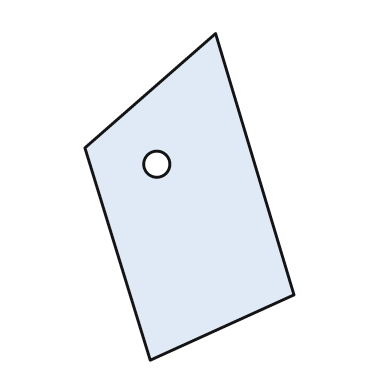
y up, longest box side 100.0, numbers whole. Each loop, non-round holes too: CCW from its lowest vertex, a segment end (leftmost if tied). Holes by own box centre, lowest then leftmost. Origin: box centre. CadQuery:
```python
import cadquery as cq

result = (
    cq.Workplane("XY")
    .moveTo(-12.0, -50.0)
    .lineTo(32.0, -30.0)
    .lineTo(8.0, 50.0)
    .lineTo(-32.0, 15.0)
    .close()
    .moveTo(-10.0, 10.0)
    .circle(4.0)
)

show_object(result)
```